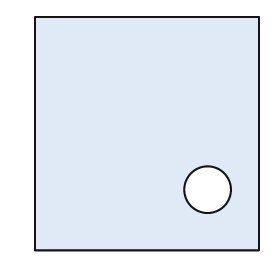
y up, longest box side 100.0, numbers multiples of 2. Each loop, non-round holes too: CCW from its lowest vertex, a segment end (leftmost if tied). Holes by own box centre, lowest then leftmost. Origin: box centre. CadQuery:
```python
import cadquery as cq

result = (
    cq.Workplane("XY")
    .moveTo(-48.0, -50.0)
    .lineTo(48.0, -50.0)
    .lineTo(48.0, 50.0)
    .lineTo(-48.0, 50.0)
    .close()
    .moveTo(26.0, -24.0)
    .circle(10.0)
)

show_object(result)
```